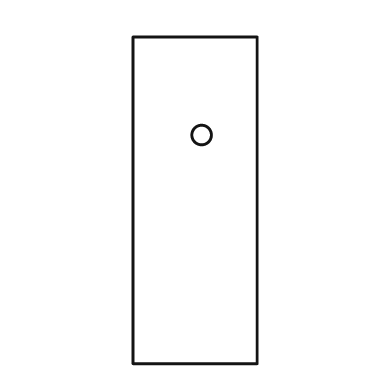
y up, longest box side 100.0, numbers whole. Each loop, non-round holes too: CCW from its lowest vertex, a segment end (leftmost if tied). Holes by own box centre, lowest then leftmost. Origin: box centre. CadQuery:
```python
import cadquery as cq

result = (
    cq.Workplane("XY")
    .moveTo(-19.0, -50.0)
    .lineTo(19.0, -50.0)
    .lineTo(19.0, 50.0)
    .lineTo(-19.0, 50.0)
    .close()
    .moveTo(2.0, 20.0)
    .circle(3.0)
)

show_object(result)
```